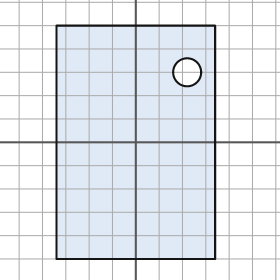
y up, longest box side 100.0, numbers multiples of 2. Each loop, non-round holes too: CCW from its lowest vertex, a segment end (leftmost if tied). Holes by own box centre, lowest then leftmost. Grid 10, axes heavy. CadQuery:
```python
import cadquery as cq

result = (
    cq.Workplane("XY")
    .moveTo(-34.0, -50.0)
    .lineTo(34.0, -50.0)
    .lineTo(34.0, 50.0)
    .lineTo(-34.0, 50.0)
    .close()
    .moveTo(22.0, 30.0)
    .circle(6.0)
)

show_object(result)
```